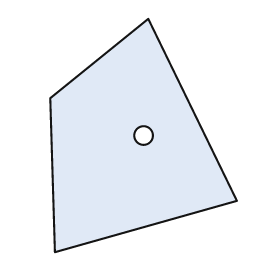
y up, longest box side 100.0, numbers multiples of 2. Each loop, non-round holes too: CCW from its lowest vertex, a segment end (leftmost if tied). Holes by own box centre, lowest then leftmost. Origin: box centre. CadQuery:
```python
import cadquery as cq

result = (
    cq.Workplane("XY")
    .moveTo(-38.0, -50.0)
    .lineTo(40.0, -28.0)
    .lineTo(2.0, 50.0)
    .lineTo(-40.0, 16.0)
    .close()
    .moveTo(0.0, 0.0)
    .circle(4.0)
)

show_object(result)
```